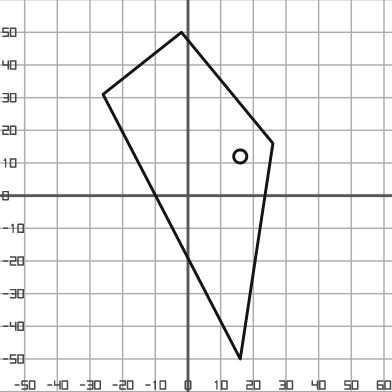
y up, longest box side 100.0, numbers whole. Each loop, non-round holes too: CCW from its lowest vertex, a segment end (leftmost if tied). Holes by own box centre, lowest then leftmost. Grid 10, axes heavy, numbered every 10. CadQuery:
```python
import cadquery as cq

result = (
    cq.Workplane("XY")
    .moveTo(16.0, -50.0)
    .lineTo(26.0, 16.0)
    .lineTo(-2.0, 50.0)
    .lineTo(-26.0, 31.0)
    .close()
    .moveTo(16.0, 12.0)
    .circle(2.0)
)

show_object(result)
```